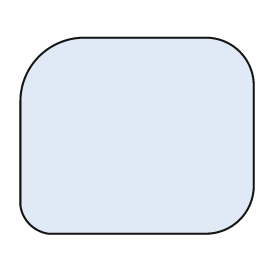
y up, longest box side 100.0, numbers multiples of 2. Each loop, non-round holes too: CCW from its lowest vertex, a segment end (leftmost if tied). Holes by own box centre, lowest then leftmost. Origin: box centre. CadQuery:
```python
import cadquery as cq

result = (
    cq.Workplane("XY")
    .moveTo(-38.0, -42.0)
    .lineTo(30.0, -42.0)
    .threePointArc((44.0, -36.0), (50.0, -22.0))
    .lineTo(50.0, 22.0)
    .threePointArc((44.0, 36.0), (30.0, 42.0))
    .lineTo(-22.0, 42.0)
    .threePointArc((-42.0, 34.0), (-50.0, 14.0))
    .lineTo(-50.0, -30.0)
    .threePointArc((-46.0, -38.0), (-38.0, -42.0))
    .close()
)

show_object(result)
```